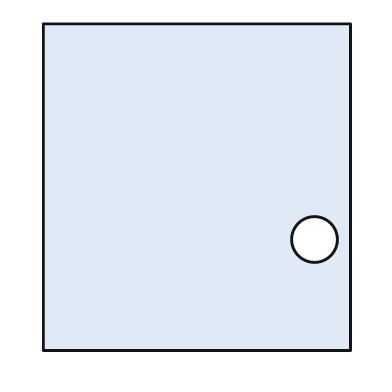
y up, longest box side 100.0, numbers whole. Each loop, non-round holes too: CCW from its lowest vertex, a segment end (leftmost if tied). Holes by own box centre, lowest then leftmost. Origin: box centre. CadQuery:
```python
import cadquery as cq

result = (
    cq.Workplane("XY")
    .moveTo(-47.0, -50.0)
    .lineTo(47.0, -50.0)
    .lineTo(47.0, 50.0)
    .lineTo(-47.0, 50.0)
    .close()
    .moveTo(36.0, -16.0)
    .circle(7.0)
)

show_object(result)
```